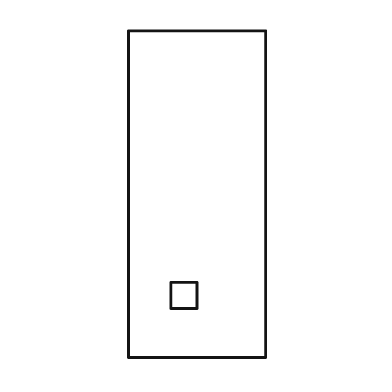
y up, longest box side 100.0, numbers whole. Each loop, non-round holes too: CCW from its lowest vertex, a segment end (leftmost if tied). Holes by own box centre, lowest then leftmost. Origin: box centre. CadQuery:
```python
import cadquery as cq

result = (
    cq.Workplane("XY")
    .moveTo(-21.0, -50.0)
    .lineTo(21.0, -50.0)
    .lineTo(21.0, 50.0)
    .lineTo(-21.0, 50.0)
    .close()
    .moveTo(-8.0, -35.0)
    .lineTo(0.0, -35.0)
    .lineTo(0.0, -27.0)
    .lineTo(-8.0, -27.0)
    .close()
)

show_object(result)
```